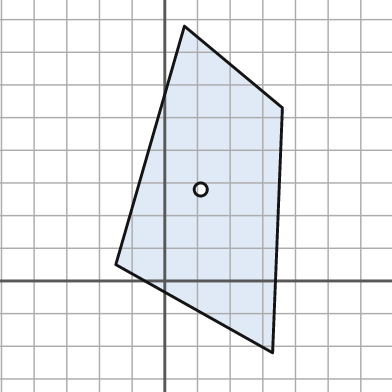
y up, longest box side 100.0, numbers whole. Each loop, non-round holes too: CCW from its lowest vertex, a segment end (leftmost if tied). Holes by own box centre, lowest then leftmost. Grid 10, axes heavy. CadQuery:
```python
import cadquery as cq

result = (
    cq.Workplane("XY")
    .moveTo(33.0, -22.0)
    .lineTo(36.0, 53.0)
    .lineTo(6.0, 78.0)
    .lineTo(-15.0, 5.0)
    .close()
    .moveTo(11.0, 28.0)
    .circle(2.0)
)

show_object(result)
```